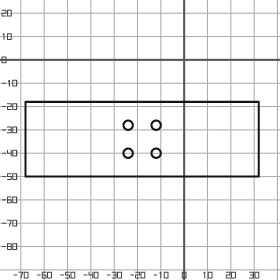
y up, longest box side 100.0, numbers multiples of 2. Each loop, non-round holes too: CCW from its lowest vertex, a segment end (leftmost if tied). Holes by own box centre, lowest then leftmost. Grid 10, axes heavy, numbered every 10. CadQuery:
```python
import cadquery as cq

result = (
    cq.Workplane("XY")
    .moveTo(-68.0, -50.0)
    .lineTo(32.0, -50.0)
    .lineTo(32.0, -18.0)
    .lineTo(-68.0, -18.0)
    .close()
    .moveTo(-24.0, -40.0)
    .circle(2.0)
    .moveTo(-12.0, -40.0)
    .circle(2.0)
    .moveTo(-24.0, -28.0)
    .circle(2.0)
    .moveTo(-12.0, -28.0)
    .circle(2.0)
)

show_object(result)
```